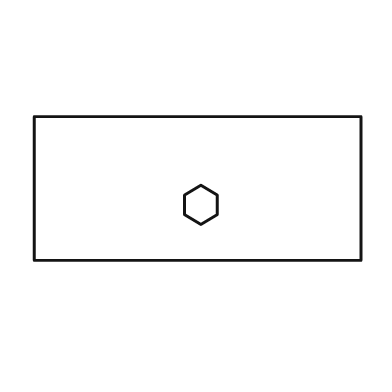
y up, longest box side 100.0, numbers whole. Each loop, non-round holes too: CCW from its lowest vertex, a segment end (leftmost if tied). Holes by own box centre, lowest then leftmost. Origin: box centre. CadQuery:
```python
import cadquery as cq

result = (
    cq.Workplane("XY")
    .moveTo(-50.0, -22.0)
    .lineTo(50.0, -22.0)
    .lineTo(50.0, 22.0)
    .lineTo(-50.0, 22.0)
    .close()
    .moveTo(1.0, -11.0)
    .lineTo(6.0, -8.0)
    .lineTo(6.0, -2.0)
    .lineTo(1.0, 1.0)
    .lineTo(-4.0, -2.0)
    .lineTo(-4.0, -8.0)
    .close()
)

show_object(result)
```